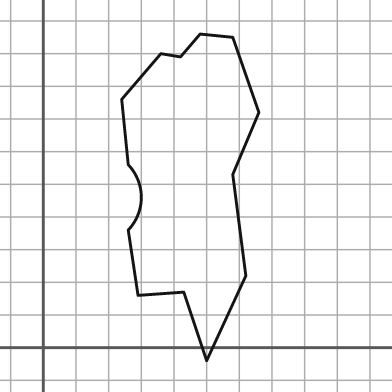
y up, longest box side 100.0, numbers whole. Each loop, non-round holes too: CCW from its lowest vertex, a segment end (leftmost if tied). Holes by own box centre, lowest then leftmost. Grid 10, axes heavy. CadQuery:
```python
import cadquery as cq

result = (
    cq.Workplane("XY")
    .moveTo(50.0, -4.0)
    .lineTo(62.0, 22.0)
    .lineTo(58.0, 53.0)
    .lineTo(66.0, 72.0)
    .lineTo(58.0, 95.0)
    .lineTo(48.0, 96.0)
    .lineTo(42.0, 89.0)
    .lineTo(36.0, 90.0)
    .lineTo(24.0, 76.0)
    .lineTo(26.0, 56.0)
    .threePointArc((30.0, 46.0), (26.0, 36.0))
    .lineTo(29.0, 16.0)
    .lineTo(43.0, 17.0)
    .close()
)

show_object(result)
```